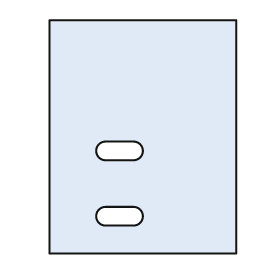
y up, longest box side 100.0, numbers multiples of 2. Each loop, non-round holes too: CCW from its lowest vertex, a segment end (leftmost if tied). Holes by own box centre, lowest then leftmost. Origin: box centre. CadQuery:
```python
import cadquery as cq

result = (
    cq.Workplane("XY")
    .moveTo(-40.0, -50.0)
    .lineTo(40.0, -50.0)
    .lineTo(40.0, 50.0)
    .lineTo(-40.0, 50.0)
    .close()
    .moveTo(-16.0, -38.0)
    .lineTo(-4.0, -38.0)
    .threePointArc((0.0, -34.0), (-4.0, -30.0))
    .lineTo(-16.0, -30.0)
    .threePointArc((-20.0, -34.0), (-16.0, -38.0))
    .close()
    .moveTo(-16.0, -10.0)
    .lineTo(-4.0, -10.0)
    .threePointArc((0.0, -6.0), (-4.0, -2.0))
    .lineTo(-16.0, -2.0)
    .threePointArc((-20.0, -6.0), (-16.0, -10.0))
    .close()
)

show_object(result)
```